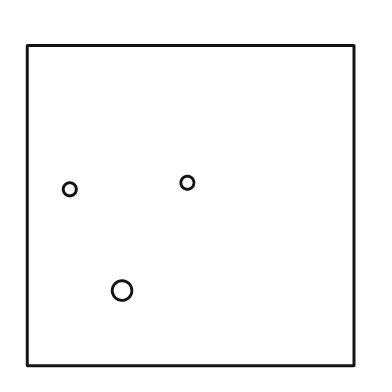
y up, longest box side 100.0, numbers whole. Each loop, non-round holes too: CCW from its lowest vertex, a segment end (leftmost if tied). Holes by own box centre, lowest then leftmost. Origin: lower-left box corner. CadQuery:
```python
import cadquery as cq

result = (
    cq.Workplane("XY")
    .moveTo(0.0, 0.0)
    .lineTo(100.0, 0.0)
    .lineTo(100.0, 98.0)
    .lineTo(0.0, 98.0)
    .close()
    .moveTo(29.0, 23.0)
    .circle(3.0)
    .moveTo(13.0, 54.0)
    .circle(2.0)
    .moveTo(49.0, 56.0)
    .circle(2.0)
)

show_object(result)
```